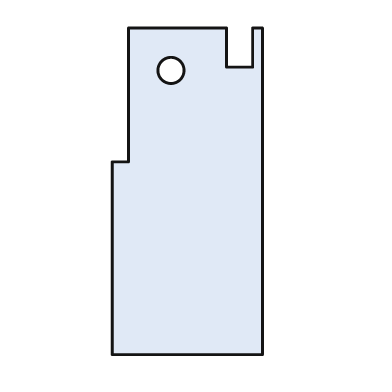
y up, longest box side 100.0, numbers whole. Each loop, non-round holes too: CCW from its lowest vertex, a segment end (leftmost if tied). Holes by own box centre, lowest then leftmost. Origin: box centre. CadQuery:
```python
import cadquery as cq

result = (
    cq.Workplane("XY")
    .moveTo(-23.0, -50.0)
    .lineTo(23.0, -50.0)
    .lineTo(23.0, 50.0)
    .lineTo(20.0, 50.0)
    .lineTo(20.0, 38.0)
    .lineTo(12.0, 38.0)
    .lineTo(12.0, 50.0)
    .lineTo(-18.0, 50.0)
    .lineTo(-18.0, 9.0)
    .lineTo(-23.0, 9.0)
    .close()
    .moveTo(-5.0, 37.0)
    .circle(4.0)
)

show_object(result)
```